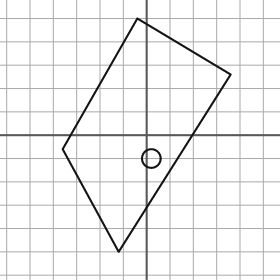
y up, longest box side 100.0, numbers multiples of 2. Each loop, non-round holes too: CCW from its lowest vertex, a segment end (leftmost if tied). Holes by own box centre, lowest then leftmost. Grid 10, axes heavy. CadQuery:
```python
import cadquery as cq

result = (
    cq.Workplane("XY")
    .moveTo(-12.0, -50.0)
    .lineTo(36.0, 26.0)
    .lineTo(-4.0, 50.0)
    .lineTo(-36.0, -6.0)
    .close()
    .moveTo(2.0, -10.0)
    .circle(4.0)
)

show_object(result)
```